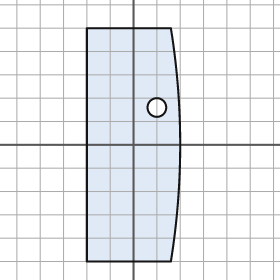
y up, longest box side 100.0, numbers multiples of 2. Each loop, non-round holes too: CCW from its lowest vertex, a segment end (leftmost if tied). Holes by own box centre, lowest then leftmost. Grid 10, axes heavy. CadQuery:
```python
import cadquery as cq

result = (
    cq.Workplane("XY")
    .moveTo(-20.0, -50.0)
    .lineTo(16.0, -50.0)
    .threePointArc((20.0, 0.0), (16.0, 50.0))
    .lineTo(-20.0, 50.0)
    .close()
    .moveTo(10.0, 16.0)
    .circle(4.0)
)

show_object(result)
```